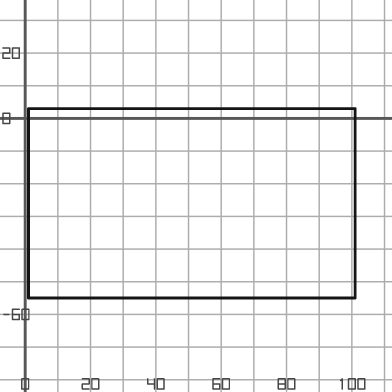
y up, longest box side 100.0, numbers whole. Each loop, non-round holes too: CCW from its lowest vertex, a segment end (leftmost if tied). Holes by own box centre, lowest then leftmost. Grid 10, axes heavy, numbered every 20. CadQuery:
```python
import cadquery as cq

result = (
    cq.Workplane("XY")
    .moveTo(1.0, -55.0)
    .lineTo(101.0, -55.0)
    .lineTo(101.0, 3.0)
    .lineTo(1.0, 3.0)
    .close()
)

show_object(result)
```